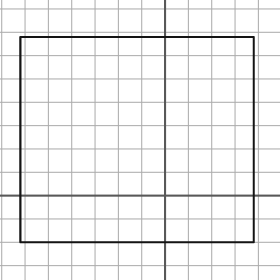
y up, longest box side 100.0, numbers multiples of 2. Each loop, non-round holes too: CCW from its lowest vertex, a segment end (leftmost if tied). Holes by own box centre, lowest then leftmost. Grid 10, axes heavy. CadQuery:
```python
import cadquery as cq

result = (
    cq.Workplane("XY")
    .moveTo(-62.0, -20.0)
    .lineTo(38.0, -20.0)
    .lineTo(38.0, 68.0)
    .lineTo(-62.0, 68.0)
    .close()
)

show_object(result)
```